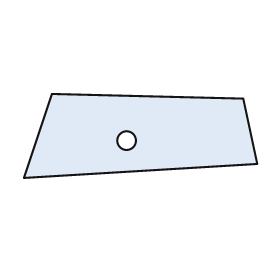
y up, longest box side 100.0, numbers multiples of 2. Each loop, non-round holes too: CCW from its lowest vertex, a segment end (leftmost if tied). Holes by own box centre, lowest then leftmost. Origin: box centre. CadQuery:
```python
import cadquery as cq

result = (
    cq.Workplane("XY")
    .moveTo(-50.0, -18.0)
    .lineTo(50.0, -12.0)
    .lineTo(44.0, 16.0)
    .lineTo(-38.0, 18.0)
    .close()
    .moveTo(-6.0, -2.0)
    .circle(4.0)
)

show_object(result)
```